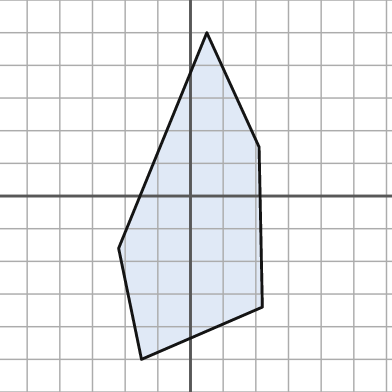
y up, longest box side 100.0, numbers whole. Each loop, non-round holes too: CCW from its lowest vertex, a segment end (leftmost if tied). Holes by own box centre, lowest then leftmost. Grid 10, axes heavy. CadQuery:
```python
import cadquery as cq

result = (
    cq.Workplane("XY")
    .moveTo(-15.0, -50.0)
    .lineTo(22.0, -34.0)
    .lineTo(21.0, 15.0)
    .lineTo(5.0, 50.0)
    .lineTo(-22.0, -16.0)
    .close()
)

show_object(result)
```